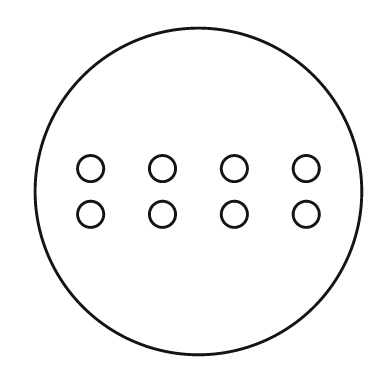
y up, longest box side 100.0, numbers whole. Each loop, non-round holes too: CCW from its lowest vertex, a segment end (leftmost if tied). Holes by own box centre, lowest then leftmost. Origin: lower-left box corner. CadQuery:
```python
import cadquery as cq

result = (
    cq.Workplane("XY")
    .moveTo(50.0, 50.0)
    .circle(50.0)
    .moveTo(17.0, 43.0)
    .circle(4.0)
    .moveTo(39.0, 43.0)
    .circle(4.0)
    .moveTo(61.0, 43.0)
    .circle(4.0)
    .moveTo(83.0, 43.0)
    .circle(4.0)
    .moveTo(17.0, 57.0)
    .circle(4.0)
    .moveTo(39.0, 57.0)
    .circle(4.0)
    .moveTo(61.0, 57.0)
    .circle(4.0)
    .moveTo(83.0, 57.0)
    .circle(4.0)
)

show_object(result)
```